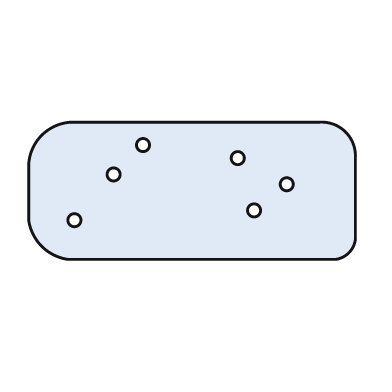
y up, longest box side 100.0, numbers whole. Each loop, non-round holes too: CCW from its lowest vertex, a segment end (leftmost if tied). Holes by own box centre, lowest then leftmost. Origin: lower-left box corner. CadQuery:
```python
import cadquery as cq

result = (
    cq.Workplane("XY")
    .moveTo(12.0, 0.0)
    .lineTo(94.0, 0.0)
    .threePointArc((98.0, 2.0), (100.0, 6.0))
    .lineTo(100.0, 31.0)
    .threePointArc((97.0, 39.0), (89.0, 42.0))
    .lineTo(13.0, 42.0)
    .threePointArc((4.0, 38.0), (0.0, 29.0))
    .lineTo(0.0, 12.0)
    .threePointArc((4.0, 4.0), (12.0, 0.0))
    .close()
    .moveTo(14.0, 12.0)
    .circle(2.0)
    .moveTo(69.0, 15.0)
    .circle(2.0)
    .moveTo(79.0, 23.0)
    .circle(2.0)
    .moveTo(26.0, 26.0)
    .circle(2.0)
    .moveTo(64.0, 31.0)
    .circle(2.0)
    .moveTo(35.0, 35.0)
    .circle(2.0)
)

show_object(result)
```